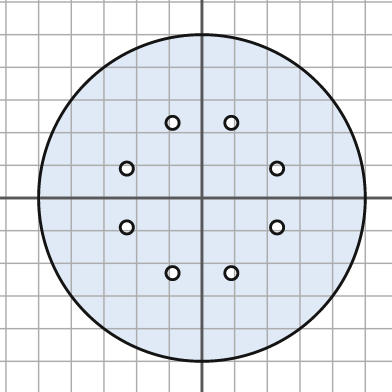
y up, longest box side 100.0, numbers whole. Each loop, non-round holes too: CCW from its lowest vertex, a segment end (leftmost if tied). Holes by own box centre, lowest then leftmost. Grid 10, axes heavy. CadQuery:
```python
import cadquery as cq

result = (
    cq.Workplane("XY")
    .moveTo(0.0, 0.0)
    .circle(50.0)
    .moveTo(-9.0, -23.0)
    .circle(2.0)
    .moveTo(9.0, -23.0)
    .circle(2.0)
    .moveTo(-23.0, -9.0)
    .circle(2.0)
    .moveTo(23.0, -9.0)
    .circle(2.0)
    .moveTo(-23.0, 9.0)
    .circle(2.0)
    .moveTo(23.0, 9.0)
    .circle(2.0)
    .moveTo(-9.0, 23.0)
    .circle(2.0)
    .moveTo(9.0, 23.0)
    .circle(2.0)
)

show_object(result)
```